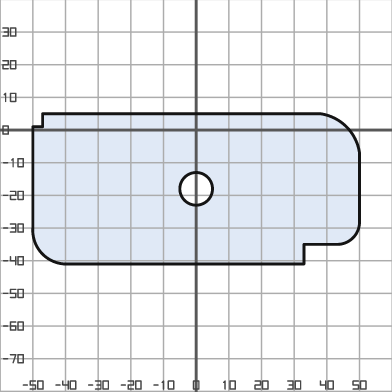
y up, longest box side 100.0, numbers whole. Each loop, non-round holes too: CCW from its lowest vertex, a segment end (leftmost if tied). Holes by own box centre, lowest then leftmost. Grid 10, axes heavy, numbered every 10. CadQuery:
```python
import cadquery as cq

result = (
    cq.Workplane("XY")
    .moveTo(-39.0, -41.0)
    .lineTo(33.0, -41.0)
    .lineTo(33.0, -35.0)
    .lineTo(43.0, -35.0)
    .threePointArc((48.0, -33.0), (50.0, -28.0))
    .lineTo(50.0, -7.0)
    .threePointArc((46.0, 1.0), (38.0, 5.0))
    .lineTo(-47.0, 5.0)
    .lineTo(-47.0, 1.0)
    .lineTo(-50.0, 1.0)
    .lineTo(-50.0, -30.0)
    .threePointArc((-47.0, -38.0), (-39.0, -41.0))
    .close()
    .moveTo(0.0, -18.0)
    .circle(5.0)
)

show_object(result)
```